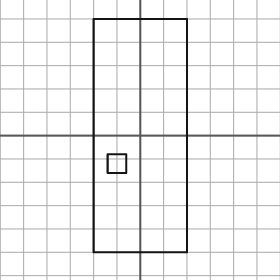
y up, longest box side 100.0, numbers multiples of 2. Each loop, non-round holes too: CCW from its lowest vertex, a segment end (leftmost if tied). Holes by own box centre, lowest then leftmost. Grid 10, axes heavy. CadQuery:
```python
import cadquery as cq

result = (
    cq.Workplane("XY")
    .moveTo(-20.0, -50.0)
    .lineTo(20.0, -50.0)
    .lineTo(20.0, 50.0)
    .lineTo(-20.0, 50.0)
    .close()
    .moveTo(-14.0, -16.0)
    .lineTo(-6.0, -16.0)
    .lineTo(-6.0, -8.0)
    .lineTo(-14.0, -8.0)
    .close()
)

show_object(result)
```